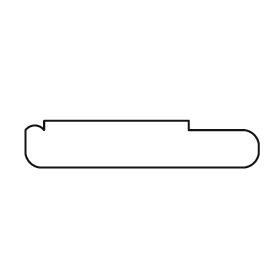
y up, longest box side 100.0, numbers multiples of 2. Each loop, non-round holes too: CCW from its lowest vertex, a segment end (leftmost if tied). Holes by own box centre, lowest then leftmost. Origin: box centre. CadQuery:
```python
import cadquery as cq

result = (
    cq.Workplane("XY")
    .moveTo(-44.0, -10.0)
    .lineTo(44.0, -10.0)
    .threePointArc((48.0, -8.0), (50.0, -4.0))
    .lineTo(50.0, 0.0)
    .threePointArc((48.0, 4.0), (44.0, 6.0))
    .lineTo(20.0, 6.0)
    .lineTo(20.0, 10.0)
    .lineTo(-42.0, 10.0)
    .lineTo(-42.0, 6.0)
    .threePointArc((-46.0, 8.0), (-50.0, 6.0))
    .lineTo(-50.0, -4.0)
    .threePointArc((-48.0, -8.0), (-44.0, -10.0))
    .close()
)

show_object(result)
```